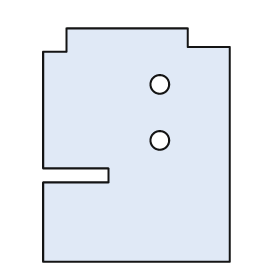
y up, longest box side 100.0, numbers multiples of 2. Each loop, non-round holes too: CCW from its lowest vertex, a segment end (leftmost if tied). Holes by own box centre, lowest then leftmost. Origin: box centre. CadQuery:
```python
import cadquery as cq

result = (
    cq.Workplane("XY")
    .moveTo(-40.0, -50.0)
    .lineTo(40.0, -50.0)
    .lineTo(40.0, 42.0)
    .lineTo(22.0, 42.0)
    .lineTo(22.0, 50.0)
    .lineTo(-30.0, 50.0)
    .lineTo(-30.0, 40.0)
    .lineTo(-40.0, 40.0)
    .lineTo(-40.0, -10.0)
    .lineTo(-12.0, -10.0)
    .lineTo(-12.0, -16.0)
    .lineTo(-40.0, -16.0)
    .close()
    .moveTo(10.0, 2.0)
    .circle(4.0)
    .moveTo(10.0, 26.0)
    .circle(4.0)
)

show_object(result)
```